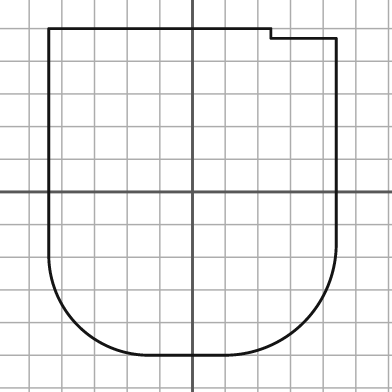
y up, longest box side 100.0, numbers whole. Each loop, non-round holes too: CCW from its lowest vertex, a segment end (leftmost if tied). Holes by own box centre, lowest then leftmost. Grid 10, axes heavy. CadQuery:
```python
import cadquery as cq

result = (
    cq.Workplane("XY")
    .moveTo(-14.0, -50.0)
    .lineTo(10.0, -50.0)
    .threePointArc((34.0, -40.0), (44.0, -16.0))
    .lineTo(44.0, 47.0)
    .lineTo(24.0, 47.0)
    .lineTo(24.0, 50.0)
    .lineTo(-44.0, 50.0)
    .lineTo(-44.0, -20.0)
    .threePointArc((-35.0, -41.0), (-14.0, -50.0))
    .close()
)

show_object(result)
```